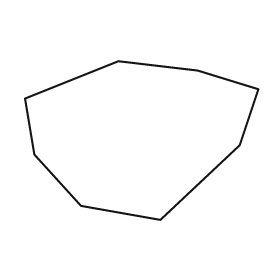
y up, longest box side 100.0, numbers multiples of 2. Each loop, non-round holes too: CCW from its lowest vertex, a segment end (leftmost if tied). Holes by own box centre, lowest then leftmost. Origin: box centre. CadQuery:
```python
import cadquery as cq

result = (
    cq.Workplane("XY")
    .moveTo(8.0, -34.0)
    .lineTo(42.0, -2.0)
    .lineTo(50.0, 22.0)
    .lineTo(24.0, 30.0)
    .lineTo(-10.0, 34.0)
    .lineTo(-50.0, 18.0)
    .lineTo(-46.0, -6.0)
    .lineTo(-26.0, -28.0)
    .close()
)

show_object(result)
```